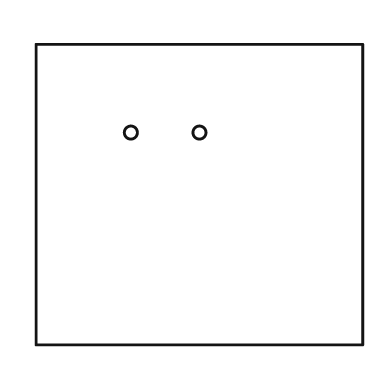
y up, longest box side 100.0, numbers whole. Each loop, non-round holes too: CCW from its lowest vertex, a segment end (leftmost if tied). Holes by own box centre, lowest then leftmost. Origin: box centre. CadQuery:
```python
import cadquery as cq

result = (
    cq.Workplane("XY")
    .moveTo(-50.0, -46.0)
    .lineTo(50.0, -46.0)
    .lineTo(50.0, 46.0)
    .lineTo(-50.0, 46.0)
    .close()
    .moveTo(-21.0, 19.0)
    .circle(2.0)
    .moveTo(0.0, 19.0)
    .circle(2.0)
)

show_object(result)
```